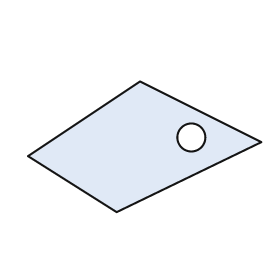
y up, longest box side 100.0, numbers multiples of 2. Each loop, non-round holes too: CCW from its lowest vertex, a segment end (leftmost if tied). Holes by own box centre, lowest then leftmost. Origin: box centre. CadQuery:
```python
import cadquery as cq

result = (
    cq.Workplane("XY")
    .moveTo(-12.0, -28.0)
    .lineTo(50.0, 2.0)
    .lineTo(-2.0, 28.0)
    .lineTo(-50.0, -4.0)
    .close()
    .moveTo(20.0, 4.0)
    .circle(6.0)
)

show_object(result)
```